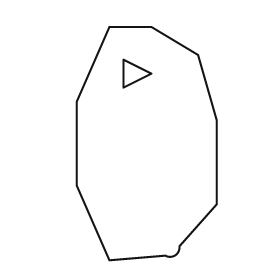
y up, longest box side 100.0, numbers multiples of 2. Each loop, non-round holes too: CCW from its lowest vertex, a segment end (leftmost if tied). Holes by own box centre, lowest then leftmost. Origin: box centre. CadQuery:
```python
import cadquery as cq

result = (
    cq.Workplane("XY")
    .moveTo(-16.0, -50.0)
    .lineTo(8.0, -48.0)
    .threePointArc((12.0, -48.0), (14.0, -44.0))
    .lineTo(30.0, -26.0)
    .lineTo(30.0, 10.0)
    .lineTo(22.0, 38.0)
    .lineTo(2.0, 50.0)
    .lineTo(-16.0, 50.0)
    .lineTo(-30.0, 18.0)
    .lineTo(-30.0, -18.0)
    .close()
    .moveTo(-10.0, 24.0)
    .lineTo(2.0, 30.0)
    .lineTo(-10.0, 36.0)
    .close()
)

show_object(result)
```